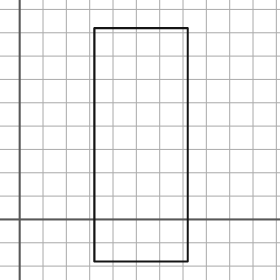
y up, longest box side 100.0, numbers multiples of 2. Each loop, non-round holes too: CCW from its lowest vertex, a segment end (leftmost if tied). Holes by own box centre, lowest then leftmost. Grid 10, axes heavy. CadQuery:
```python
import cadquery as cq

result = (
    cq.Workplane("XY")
    .moveTo(32.0, -18.0)
    .lineTo(72.0, -18.0)
    .lineTo(72.0, 82.0)
    .lineTo(32.0, 82.0)
    .close()
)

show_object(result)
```